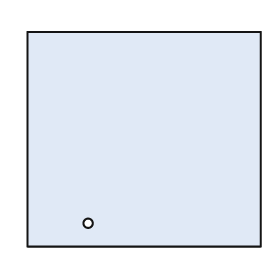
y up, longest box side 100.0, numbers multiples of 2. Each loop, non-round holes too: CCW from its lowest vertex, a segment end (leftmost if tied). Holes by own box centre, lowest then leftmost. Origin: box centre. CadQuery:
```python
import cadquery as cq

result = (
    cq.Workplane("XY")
    .moveTo(-50.0, -46.0)
    .lineTo(50.0, -46.0)
    .lineTo(50.0, 46.0)
    .lineTo(-50.0, 46.0)
    .close()
    .moveTo(-24.0, -36.0)
    .circle(2.0)
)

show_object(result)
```